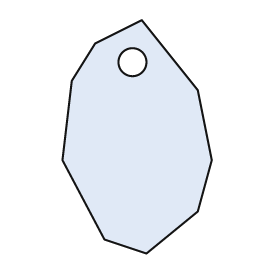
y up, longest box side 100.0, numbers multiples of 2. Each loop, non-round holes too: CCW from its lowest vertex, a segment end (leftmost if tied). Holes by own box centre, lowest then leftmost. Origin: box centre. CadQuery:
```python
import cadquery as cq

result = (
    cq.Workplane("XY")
    .moveTo(4.0, -50.0)
    .lineTo(26.0, -32.0)
    .lineTo(32.0, -10.0)
    .lineTo(26.0, 20.0)
    .lineTo(2.0, 50.0)
    .lineTo(-18.0, 40.0)
    .lineTo(-28.0, 24.0)
    .lineTo(-32.0, -10.0)
    .lineTo(-14.0, -44.0)
    .close()
    .moveTo(-2.0, 32.0)
    .circle(6.0)
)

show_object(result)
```